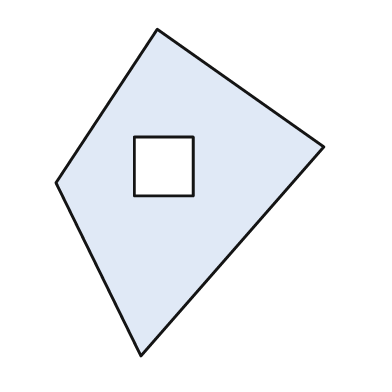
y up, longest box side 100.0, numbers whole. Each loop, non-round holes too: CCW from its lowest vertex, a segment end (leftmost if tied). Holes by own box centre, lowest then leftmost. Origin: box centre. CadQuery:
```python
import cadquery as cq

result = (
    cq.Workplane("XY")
    .moveTo(-15.0, -50.0)
    .lineTo(41.0, 14.0)
    .lineTo(-10.0, 50.0)
    .lineTo(-41.0, 3.0)
    .close()
    .moveTo(-17.0, -1.0)
    .lineTo(1.0, -1.0)
    .lineTo(1.0, 17.0)
    .lineTo(-17.0, 17.0)
    .close()
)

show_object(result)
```